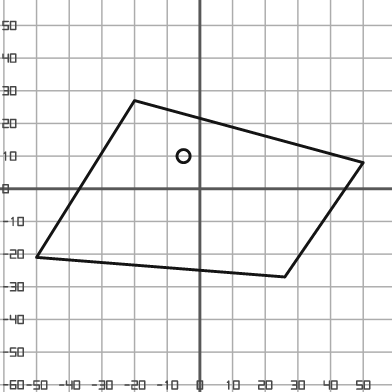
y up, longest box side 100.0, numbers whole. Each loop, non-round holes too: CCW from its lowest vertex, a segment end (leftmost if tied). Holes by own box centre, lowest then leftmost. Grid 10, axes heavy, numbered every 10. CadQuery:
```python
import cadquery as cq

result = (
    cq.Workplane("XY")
    .moveTo(26.0, -27.0)
    .lineTo(50.0, 8.0)
    .lineTo(-20.0, 27.0)
    .lineTo(-50.0, -21.0)
    .close()
    .moveTo(-5.0, 10.0)
    .circle(2.0)
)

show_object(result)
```